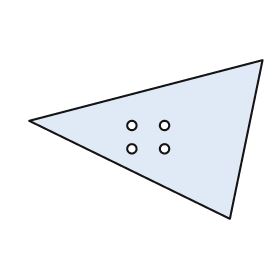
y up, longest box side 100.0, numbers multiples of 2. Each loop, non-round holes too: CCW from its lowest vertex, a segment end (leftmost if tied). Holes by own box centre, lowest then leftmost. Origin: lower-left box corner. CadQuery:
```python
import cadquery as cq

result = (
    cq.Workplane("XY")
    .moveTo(86.0, 0.0)
    .lineTo(100.0, 68.0)
    .lineTo(0.0, 42.0)
    .close()
    .moveTo(44.0, 30.0)
    .circle(2.0)
    .moveTo(58.0, 30.0)
    .circle(2.0)
    .moveTo(44.0, 40.0)
    .circle(2.0)
    .moveTo(58.0, 40.0)
    .circle(2.0)
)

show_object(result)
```